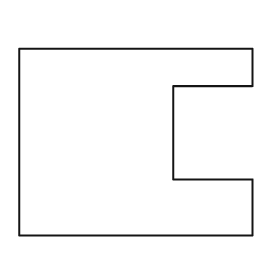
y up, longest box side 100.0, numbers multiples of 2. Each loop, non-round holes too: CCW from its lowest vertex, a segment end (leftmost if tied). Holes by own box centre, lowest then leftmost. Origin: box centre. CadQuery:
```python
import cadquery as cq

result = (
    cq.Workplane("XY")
    .moveTo(-50.0, -40.0)
    .lineTo(50.0, -40.0)
    .lineTo(50.0, -16.0)
    .lineTo(16.0, -16.0)
    .lineTo(16.0, 24.0)
    .lineTo(50.0, 24.0)
    .lineTo(50.0, 40.0)
    .lineTo(-50.0, 40.0)
    .close()
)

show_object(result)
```